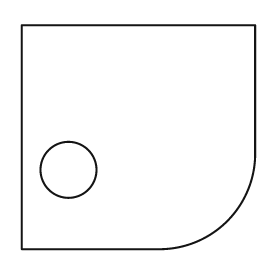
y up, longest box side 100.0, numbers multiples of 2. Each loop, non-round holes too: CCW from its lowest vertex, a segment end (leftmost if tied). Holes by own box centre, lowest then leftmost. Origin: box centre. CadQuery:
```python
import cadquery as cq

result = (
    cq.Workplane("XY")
    .moveTo(-50.0, -48.0)
    .lineTo(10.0, -48.0)
    .threePointArc((38.0, -36.0), (50.0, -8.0))
    .lineTo(50.0, 48.0)
    .lineTo(-50.0, 48.0)
    .close()
    .moveTo(-30.0, -14.0)
    .circle(12.0)
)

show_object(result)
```